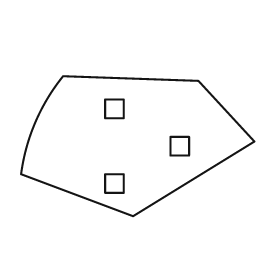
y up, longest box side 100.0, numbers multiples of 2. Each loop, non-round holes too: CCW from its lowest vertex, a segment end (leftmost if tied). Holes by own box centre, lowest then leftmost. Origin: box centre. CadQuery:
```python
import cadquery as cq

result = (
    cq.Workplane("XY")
    .moveTo(-2.0, -30.0)
    .lineTo(50.0, 2.0)
    .lineTo(26.0, 28.0)
    .lineTo(-32.0, 30.0)
    .threePointArc((-44.0, 10.0), (-50.0, -12.0))
    .close()
    .moveTo(-14.0, -20.0)
    .lineTo(-6.0, -20.0)
    .lineTo(-6.0, -12.0)
    .lineTo(-14.0, -12.0)
    .close()
    .moveTo(14.0, -4.0)
    .lineTo(22.0, -4.0)
    .lineTo(22.0, 4.0)
    .lineTo(14.0, 4.0)
    .close()
    .moveTo(-14.0, 12.0)
    .lineTo(-6.0, 12.0)
    .lineTo(-6.0, 20.0)
    .lineTo(-14.0, 20.0)
    .close()
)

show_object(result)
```